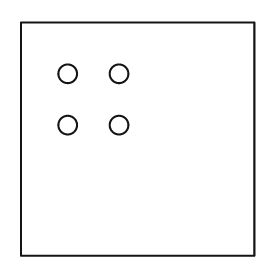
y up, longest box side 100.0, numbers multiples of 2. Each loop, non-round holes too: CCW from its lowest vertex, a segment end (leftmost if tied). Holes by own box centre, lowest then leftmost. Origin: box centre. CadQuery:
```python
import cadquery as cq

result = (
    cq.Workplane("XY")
    .moveTo(-50.0, -50.0)
    .lineTo(50.0, -50.0)
    .lineTo(50.0, 50.0)
    .lineTo(-50.0, 50.0)
    .close()
    .moveTo(-30.0, 6.0)
    .circle(4.0)
    .moveTo(-8.0, 6.0)
    .circle(4.0)
    .moveTo(-30.0, 28.0)
    .circle(4.0)
    .moveTo(-8.0, 28.0)
    .circle(4.0)
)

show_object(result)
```